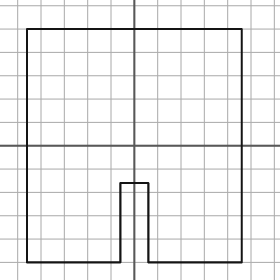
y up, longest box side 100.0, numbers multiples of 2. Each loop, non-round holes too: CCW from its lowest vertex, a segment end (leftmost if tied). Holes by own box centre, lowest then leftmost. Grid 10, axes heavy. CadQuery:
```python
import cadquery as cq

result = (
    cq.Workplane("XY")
    .moveTo(-46.0, -50.0)
    .lineTo(-6.0, -50.0)
    .lineTo(-6.0, -16.0)
    .lineTo(6.0, -16.0)
    .lineTo(6.0, -50.0)
    .lineTo(46.0, -50.0)
    .lineTo(46.0, 50.0)
    .lineTo(-46.0, 50.0)
    .close()
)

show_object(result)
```